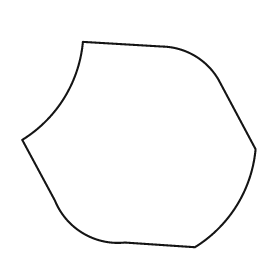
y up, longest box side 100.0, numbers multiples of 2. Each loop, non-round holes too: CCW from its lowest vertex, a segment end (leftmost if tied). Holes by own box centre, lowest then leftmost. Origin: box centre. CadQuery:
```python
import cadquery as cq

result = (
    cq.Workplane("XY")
    .moveTo(24.0, -44.0)
    .threePointArc((42.0, -26.0), (50.0, -2.0))
    .lineTo(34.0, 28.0)
    .threePointArc((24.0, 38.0), (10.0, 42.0))
    .lineTo(-24.0, 44.0)
    .threePointArc((-32.0, 20.0), (-50.0, 2.0))
    .lineTo(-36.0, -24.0)
    .threePointArc((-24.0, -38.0), (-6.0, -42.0))
    .close()
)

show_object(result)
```